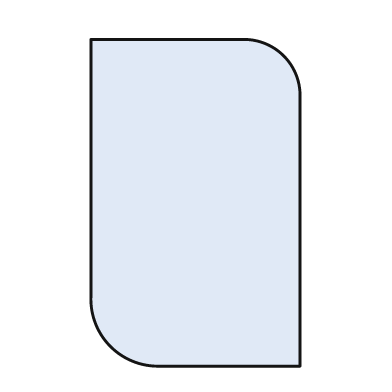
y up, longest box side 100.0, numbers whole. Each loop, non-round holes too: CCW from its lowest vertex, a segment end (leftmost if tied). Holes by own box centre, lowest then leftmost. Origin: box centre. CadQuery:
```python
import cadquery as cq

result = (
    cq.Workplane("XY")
    .moveTo(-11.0, -50.0)
    .lineTo(32.0, -50.0)
    .lineTo(32.0, 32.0)
    .threePointArc((27.0, 45.0), (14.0, 50.0))
    .lineTo(-32.0, 50.0)
    .lineTo(-32.0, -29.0)
    .threePointArc((-26.0, -44.0), (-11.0, -50.0))
    .close()
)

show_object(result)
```